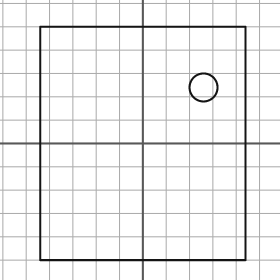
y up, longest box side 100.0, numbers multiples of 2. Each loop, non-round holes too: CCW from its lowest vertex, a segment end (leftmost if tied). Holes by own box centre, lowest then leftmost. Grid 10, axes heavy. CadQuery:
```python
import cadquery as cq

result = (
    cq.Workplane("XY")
    .moveTo(-44.0, -50.0)
    .lineTo(44.0, -50.0)
    .lineTo(44.0, 50.0)
    .lineTo(-44.0, 50.0)
    .close()
    .moveTo(26.0, 24.0)
    .circle(6.0)
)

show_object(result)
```